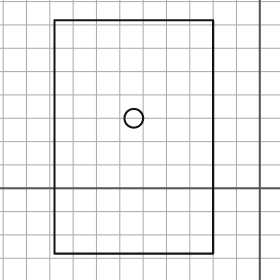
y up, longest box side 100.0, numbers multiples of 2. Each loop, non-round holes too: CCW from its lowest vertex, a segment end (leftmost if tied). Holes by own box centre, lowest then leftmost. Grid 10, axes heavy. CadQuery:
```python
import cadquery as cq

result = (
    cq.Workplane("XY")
    .moveTo(-88.0, -28.0)
    .lineTo(-20.0, -28.0)
    .lineTo(-20.0, 72.0)
    .lineTo(-88.0, 72.0)
    .close()
    .moveTo(-54.0, 30.0)
    .circle(4.0)
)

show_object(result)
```